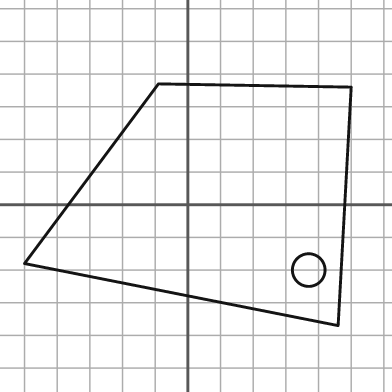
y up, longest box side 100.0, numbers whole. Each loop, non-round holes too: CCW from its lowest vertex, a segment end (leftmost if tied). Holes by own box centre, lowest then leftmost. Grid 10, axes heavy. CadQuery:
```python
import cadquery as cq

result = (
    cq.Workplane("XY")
    .moveTo(46.0, -37.0)
    .lineTo(50.0, 36.0)
    .lineTo(-9.0, 37.0)
    .lineTo(-50.0, -18.0)
    .close()
    .moveTo(37.0, -20.0)
    .circle(5.0)
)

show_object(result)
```